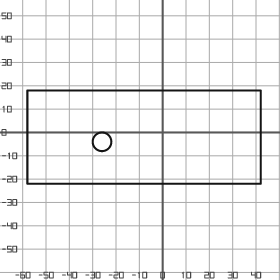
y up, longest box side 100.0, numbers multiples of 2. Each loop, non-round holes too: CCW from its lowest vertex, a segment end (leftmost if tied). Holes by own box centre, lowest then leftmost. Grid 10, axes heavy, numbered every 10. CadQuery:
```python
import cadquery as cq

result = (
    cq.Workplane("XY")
    .moveTo(-58.0, -22.0)
    .lineTo(42.0, -22.0)
    .lineTo(42.0, 18.0)
    .lineTo(-58.0, 18.0)
    .close()
    .moveTo(-26.0, -4.0)
    .circle(4.0)
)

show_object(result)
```